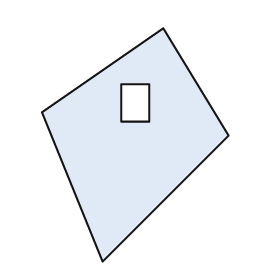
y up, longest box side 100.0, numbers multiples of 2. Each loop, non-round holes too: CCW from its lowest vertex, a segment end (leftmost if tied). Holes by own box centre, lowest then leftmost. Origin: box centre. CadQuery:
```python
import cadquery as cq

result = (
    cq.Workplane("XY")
    .moveTo(-14.0, -50.0)
    .lineTo(40.0, 4.0)
    .lineTo(12.0, 50.0)
    .lineTo(-40.0, 14.0)
    .close()
    .moveTo(-6.0, 10.0)
    .lineTo(6.0, 10.0)
    .lineTo(6.0, 26.0)
    .lineTo(-6.0, 26.0)
    .close()
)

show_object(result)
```